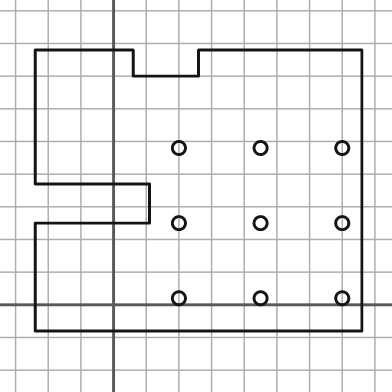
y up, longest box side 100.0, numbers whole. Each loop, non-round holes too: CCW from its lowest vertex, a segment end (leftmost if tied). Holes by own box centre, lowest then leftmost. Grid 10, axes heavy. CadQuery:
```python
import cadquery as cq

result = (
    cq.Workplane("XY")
    .moveTo(-24.0, -8.0)
    .lineTo(76.0, -8.0)
    .lineTo(76.0, 78.0)
    .lineTo(26.0, 78.0)
    .lineTo(26.0, 70.0)
    .lineTo(6.0, 70.0)
    .lineTo(6.0, 78.0)
    .lineTo(-24.0, 78.0)
    .lineTo(-24.0, 37.0)
    .lineTo(11.0, 37.0)
    .lineTo(11.0, 25.0)
    .lineTo(-24.0, 25.0)
    .close()
    .moveTo(20.0, 2.0)
    .circle(2.0)
    .moveTo(45.0, 2.0)
    .circle(2.0)
    .moveTo(70.0, 2.0)
    .circle(2.0)
    .moveTo(20.0, 25.0)
    .circle(2.0)
    .moveTo(45.0, 25.0)
    .circle(2.0)
    .moveTo(70.0, 25.0)
    .circle(2.0)
    .moveTo(20.0, 48.0)
    .circle(2.0)
    .moveTo(45.0, 48.0)
    .circle(2.0)
    .moveTo(70.0, 48.0)
    .circle(2.0)
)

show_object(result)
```